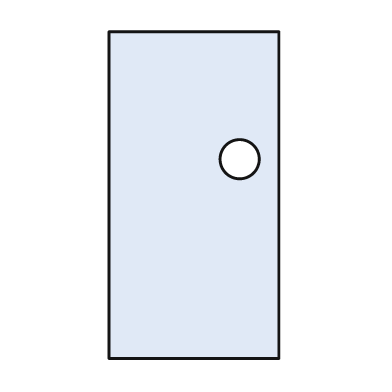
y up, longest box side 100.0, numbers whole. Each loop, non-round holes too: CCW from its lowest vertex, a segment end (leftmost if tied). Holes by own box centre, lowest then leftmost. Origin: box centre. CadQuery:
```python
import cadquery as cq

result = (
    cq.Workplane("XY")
    .moveTo(-26.0, -50.0)
    .lineTo(26.0, -50.0)
    .lineTo(26.0, 50.0)
    .lineTo(-26.0, 50.0)
    .close()
    .moveTo(14.0, 11.0)
    .circle(6.0)
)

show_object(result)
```